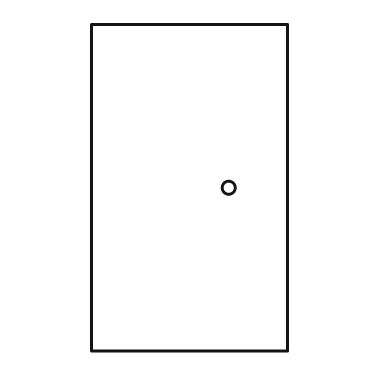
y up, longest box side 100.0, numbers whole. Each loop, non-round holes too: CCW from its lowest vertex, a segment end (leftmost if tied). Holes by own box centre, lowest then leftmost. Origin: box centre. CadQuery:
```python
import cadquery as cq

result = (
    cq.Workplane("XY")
    .moveTo(-30.0, -50.0)
    .lineTo(30.0, -50.0)
    .lineTo(30.0, 50.0)
    .lineTo(-30.0, 50.0)
    .close()
    .moveTo(12.0, 0.0)
    .circle(2.0)
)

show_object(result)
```